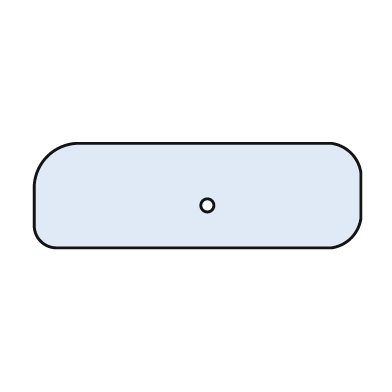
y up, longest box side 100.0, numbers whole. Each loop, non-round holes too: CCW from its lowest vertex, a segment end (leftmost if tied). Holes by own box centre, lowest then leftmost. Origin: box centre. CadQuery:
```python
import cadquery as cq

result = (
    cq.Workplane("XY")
    .moveTo(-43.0, -16.0)
    .lineTo(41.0, -16.0)
    .threePointArc((47.0, -13.0), (50.0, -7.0))
    .lineTo(50.0, 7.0)
    .threePointArc((47.0, 13.0), (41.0, 16.0))
    .lineTo(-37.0, 16.0)
    .threePointArc((-46.0, 12.0), (-50.0, 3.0))
    .lineTo(-50.0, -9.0)
    .threePointArc((-48.0, -14.0), (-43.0, -16.0))
    .close()
    .moveTo(3.0, -3.0)
    .circle(2.0)
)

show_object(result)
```